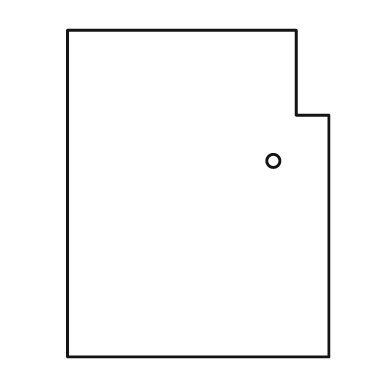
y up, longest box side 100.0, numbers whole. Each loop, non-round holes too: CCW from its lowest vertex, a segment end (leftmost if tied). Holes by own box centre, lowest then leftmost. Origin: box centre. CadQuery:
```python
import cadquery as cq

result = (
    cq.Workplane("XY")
    .moveTo(-40.0, -50.0)
    .lineTo(40.0, -50.0)
    .lineTo(40.0, 24.0)
    .lineTo(30.0, 24.0)
    .lineTo(30.0, 50.0)
    .lineTo(-40.0, 50.0)
    .close()
    .moveTo(23.0, 10.0)
    .circle(2.0)
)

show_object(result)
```